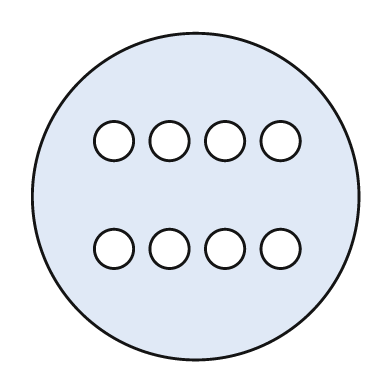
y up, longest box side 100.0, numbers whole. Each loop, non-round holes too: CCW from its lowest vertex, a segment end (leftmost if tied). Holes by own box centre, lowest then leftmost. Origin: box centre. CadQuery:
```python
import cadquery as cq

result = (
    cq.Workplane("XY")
    .moveTo(0.0, 0.0)
    .circle(50.0)
    .moveTo(-25.0, -16.0)
    .circle(6.0)
    .moveTo(-8.0, -16.0)
    .circle(6.0)
    .moveTo(9.0, -16.0)
    .circle(6.0)
    .moveTo(26.0, -16.0)
    .circle(6.0)
    .moveTo(-25.0, 17.0)
    .circle(6.0)
    .moveTo(-8.0, 17.0)
    .circle(6.0)
    .moveTo(9.0, 17.0)
    .circle(6.0)
    .moveTo(26.0, 17.0)
    .circle(6.0)
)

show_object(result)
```